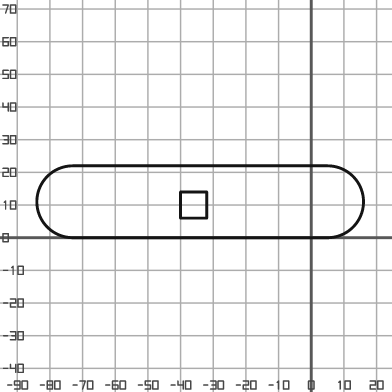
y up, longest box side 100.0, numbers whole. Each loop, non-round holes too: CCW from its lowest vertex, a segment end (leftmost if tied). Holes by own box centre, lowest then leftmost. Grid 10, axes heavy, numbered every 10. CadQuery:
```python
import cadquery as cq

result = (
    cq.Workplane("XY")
    .moveTo(-73.0, 0.0)
    .lineTo(5.0, 0.0)
    .threePointArc((16.0, 11.0), (5.0, 22.0))
    .lineTo(-73.0, 22.0)
    .threePointArc((-84.0, 11.0), (-73.0, 0.0))
    .close()
    .moveTo(-40.0, 6.0)
    .lineTo(-32.0, 6.0)
    .lineTo(-32.0, 14.0)
    .lineTo(-40.0, 14.0)
    .close()
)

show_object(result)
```